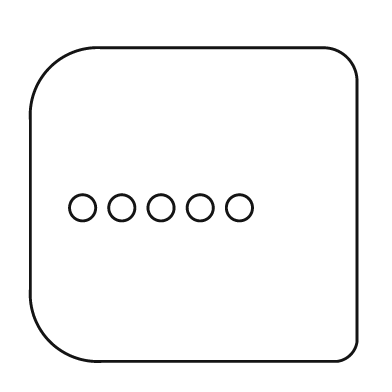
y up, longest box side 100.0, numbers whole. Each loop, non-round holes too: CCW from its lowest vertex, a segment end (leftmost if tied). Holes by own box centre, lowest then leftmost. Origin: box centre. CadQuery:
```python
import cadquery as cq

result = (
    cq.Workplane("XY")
    .moveTo(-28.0, -48.0)
    .lineTo(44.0, -48.0)
    .threePointArc((48.0, -46.0), (50.0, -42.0))
    .lineTo(50.0, 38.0)
    .threePointArc((47.0, 45.0), (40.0, 48.0))
    .lineTo(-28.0, 48.0)
    .threePointArc((-44.0, 42.0), (-50.0, 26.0))
    .lineTo(-50.0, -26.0)
    .threePointArc((-44.0, -42.0), (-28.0, -48.0))
    .close()
    .moveTo(-34.0, -1.0)
    .circle(4.0)
    .moveTo(-22.0, -1.0)
    .circle(4.0)
    .moveTo(-10.0, -1.0)
    .circle(4.0)
    .moveTo(2.0, -1.0)
    .circle(4.0)
    .moveTo(14.0, -1.0)
    .circle(4.0)
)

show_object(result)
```